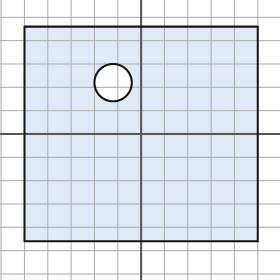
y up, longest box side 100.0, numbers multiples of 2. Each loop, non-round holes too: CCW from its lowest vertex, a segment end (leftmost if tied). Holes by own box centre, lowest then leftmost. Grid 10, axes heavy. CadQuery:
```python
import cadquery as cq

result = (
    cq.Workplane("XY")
    .moveTo(-50.0, -46.0)
    .lineTo(50.0, -46.0)
    .lineTo(50.0, 46.0)
    .lineTo(-50.0, 46.0)
    .close()
    .moveTo(-12.0, 22.0)
    .circle(8.0)
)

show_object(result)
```